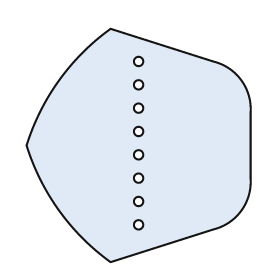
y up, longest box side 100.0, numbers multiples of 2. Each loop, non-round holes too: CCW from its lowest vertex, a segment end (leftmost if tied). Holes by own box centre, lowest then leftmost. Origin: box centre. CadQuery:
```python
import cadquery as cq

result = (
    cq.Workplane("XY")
    .moveTo(-12.0, -50.0)
    .lineTo(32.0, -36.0)
    .threePointArc((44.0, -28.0), (48.0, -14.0))
    .lineTo(48.0, 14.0)
    .threePointArc((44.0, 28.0), (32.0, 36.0))
    .lineTo(-12.0, 50.0)
    .threePointArc((-34.0, 28.0), (-48.0, 0.0))
    .threePointArc((-34.0, -28.0), (-12.0, -50.0))
    .close()
    .moveTo(0.0, -34.0)
    .circle(2.0)
    .moveTo(0.0, -24.0)
    .circle(2.0)
    .moveTo(0.0, -14.0)
    .circle(2.0)
    .moveTo(0.0, -4.0)
    .circle(2.0)
    .moveTo(0.0, 6.0)
    .circle(2.0)
    .moveTo(0.0, 16.0)
    .circle(2.0)
    .moveTo(0.0, 26.0)
    .circle(2.0)
    .moveTo(0.0, 36.0)
    .circle(2.0)
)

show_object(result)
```